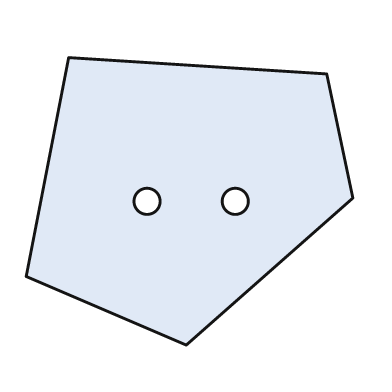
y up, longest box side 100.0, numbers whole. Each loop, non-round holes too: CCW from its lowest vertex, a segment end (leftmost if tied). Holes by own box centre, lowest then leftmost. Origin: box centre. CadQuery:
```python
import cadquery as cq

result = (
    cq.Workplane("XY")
    .moveTo(-1.0, -44.0)
    .lineTo(50.0, 1.0)
    .lineTo(42.0, 39.0)
    .lineTo(-37.0, 44.0)
    .lineTo(-50.0, -23.0)
    .close()
    .moveTo(-13.0, 0.0)
    .circle(4.0)
    .moveTo(14.0, 0.0)
    .circle(4.0)
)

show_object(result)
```